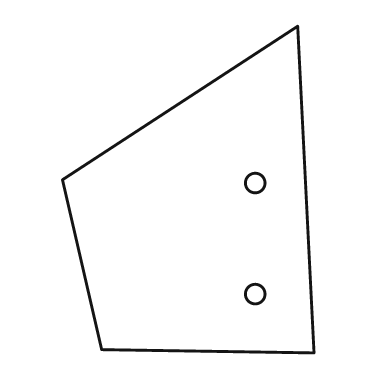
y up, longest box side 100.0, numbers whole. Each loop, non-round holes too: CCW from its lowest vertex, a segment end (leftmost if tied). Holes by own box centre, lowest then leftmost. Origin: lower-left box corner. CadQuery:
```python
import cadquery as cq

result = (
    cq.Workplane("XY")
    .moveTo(77.0, 0.0)
    .lineTo(72.0, 100.0)
    .lineTo(0.0, 53.0)
    .lineTo(12.0, 1.0)
    .close()
    .moveTo(59.0, 18.0)
    .circle(3.0)
    .moveTo(59.0, 52.0)
    .circle(3.0)
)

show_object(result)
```